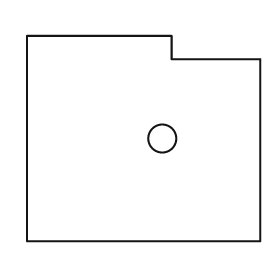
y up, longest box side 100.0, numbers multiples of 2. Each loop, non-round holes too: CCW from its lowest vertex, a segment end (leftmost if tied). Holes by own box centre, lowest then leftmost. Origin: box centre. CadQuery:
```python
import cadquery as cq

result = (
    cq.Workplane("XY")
    .moveTo(-50.0, -44.0)
    .lineTo(50.0, -44.0)
    .lineTo(50.0, 34.0)
    .lineTo(12.0, 34.0)
    .lineTo(12.0, 44.0)
    .lineTo(-50.0, 44.0)
    .close()
    .moveTo(8.0, 0.0)
    .circle(6.0)
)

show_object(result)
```